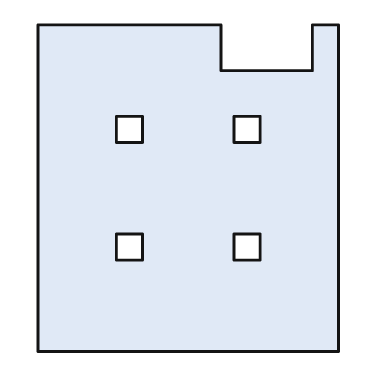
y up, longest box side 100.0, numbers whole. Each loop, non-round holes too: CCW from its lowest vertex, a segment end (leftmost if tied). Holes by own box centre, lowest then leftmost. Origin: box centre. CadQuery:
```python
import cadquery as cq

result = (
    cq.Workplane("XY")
    .moveTo(-46.0, -50.0)
    .lineTo(46.0, -50.0)
    .lineTo(46.0, 50.0)
    .lineTo(38.0, 50.0)
    .lineTo(38.0, 36.0)
    .lineTo(10.0, 36.0)
    .lineTo(10.0, 50.0)
    .lineTo(-46.0, 50.0)
    .close()
    .moveTo(-22.0, -22.0)
    .lineTo(-14.0, -22.0)
    .lineTo(-14.0, -14.0)
    .lineTo(-22.0, -14.0)
    .close()
    .moveTo(14.0, -22.0)
    .lineTo(22.0, -22.0)
    .lineTo(22.0, -14.0)
    .lineTo(14.0, -14.0)
    .close()
    .moveTo(-22.0, 14.0)
    .lineTo(-14.0, 14.0)
    .lineTo(-14.0, 22.0)
    .lineTo(-22.0, 22.0)
    .close()
    .moveTo(14.0, 14.0)
    .lineTo(22.0, 14.0)
    .lineTo(22.0, 22.0)
    .lineTo(14.0, 22.0)
    .close()
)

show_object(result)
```